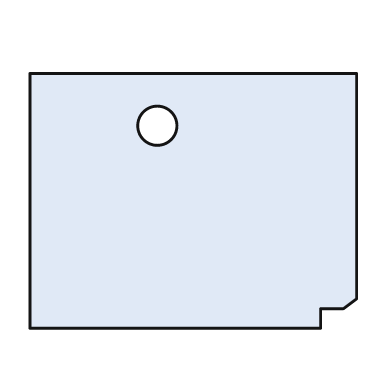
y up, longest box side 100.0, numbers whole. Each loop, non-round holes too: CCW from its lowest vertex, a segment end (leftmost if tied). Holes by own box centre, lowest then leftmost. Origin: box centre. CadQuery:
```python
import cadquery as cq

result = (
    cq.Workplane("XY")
    .moveTo(-50.0, -39.0)
    .lineTo(39.0, -39.0)
    .lineTo(39.0, -33.0)
    .lineTo(46.0, -33.0)
    .lineTo(50.0, -30.0)
    .lineTo(50.0, 39.0)
    .lineTo(-50.0, 39.0)
    .close()
    .moveTo(-11.0, 23.0)
    .circle(6.0)
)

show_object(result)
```